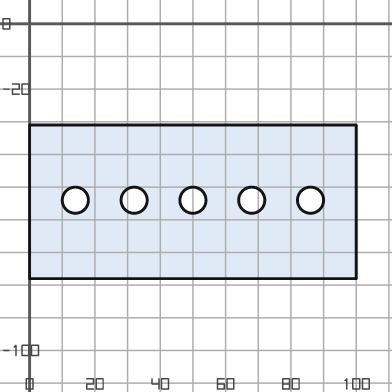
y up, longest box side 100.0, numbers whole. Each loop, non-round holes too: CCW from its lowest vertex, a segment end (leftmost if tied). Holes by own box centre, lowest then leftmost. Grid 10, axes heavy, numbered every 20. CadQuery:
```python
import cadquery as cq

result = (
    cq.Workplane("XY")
    .moveTo(0.0, -78.0)
    .lineTo(100.0, -78.0)
    .lineTo(100.0, -31.0)
    .lineTo(0.0, -31.0)
    .close()
    .moveTo(14.0, -54.0)
    .circle(4.0)
    .moveTo(32.0, -54.0)
    .circle(4.0)
    .moveTo(50.0, -54.0)
    .circle(4.0)
    .moveTo(68.0, -54.0)
    .circle(4.0)
    .moveTo(86.0, -54.0)
    .circle(4.0)
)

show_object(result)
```